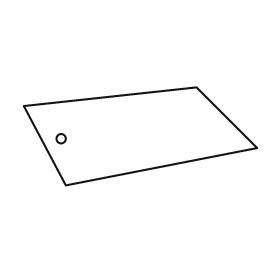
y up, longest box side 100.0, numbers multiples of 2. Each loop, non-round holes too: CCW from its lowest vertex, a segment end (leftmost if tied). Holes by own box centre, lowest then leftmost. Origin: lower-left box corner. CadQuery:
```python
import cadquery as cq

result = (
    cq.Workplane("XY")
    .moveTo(18.0, 0.0)
    .lineTo(100.0, 16.0)
    .lineTo(74.0, 42.0)
    .lineTo(0.0, 34.0)
    .close()
    .moveTo(16.0, 20.0)
    .circle(2.0)
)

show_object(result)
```